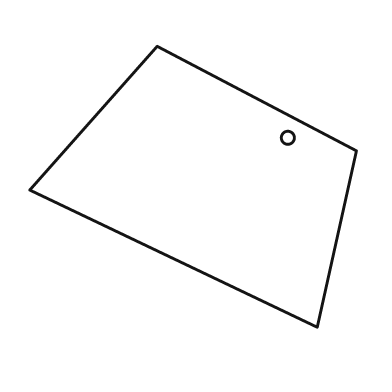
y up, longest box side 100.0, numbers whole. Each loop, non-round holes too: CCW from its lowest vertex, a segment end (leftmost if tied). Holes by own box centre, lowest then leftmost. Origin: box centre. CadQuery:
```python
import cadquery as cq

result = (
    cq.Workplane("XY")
    .moveTo(38.0, -43.0)
    .lineTo(50.0, 11.0)
    .lineTo(-11.0, 43.0)
    .lineTo(-50.0, -1.0)
    .close()
    .moveTo(29.0, 15.0)
    .circle(2.0)
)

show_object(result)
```